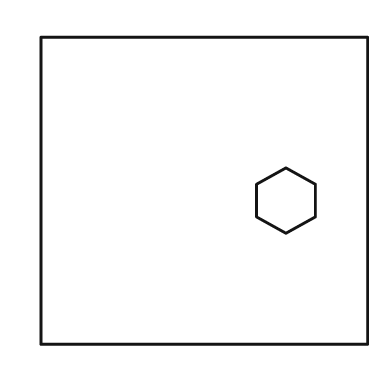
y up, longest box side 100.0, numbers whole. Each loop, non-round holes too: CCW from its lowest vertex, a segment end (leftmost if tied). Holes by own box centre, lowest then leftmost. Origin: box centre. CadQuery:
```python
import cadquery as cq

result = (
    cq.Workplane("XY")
    .moveTo(-50.0, -47.0)
    .lineTo(50.0, -47.0)
    .lineTo(50.0, 47.0)
    .lineTo(-50.0, 47.0)
    .close()
    .moveTo(25.0, -13.0)
    .lineTo(34.0, -8.0)
    .lineTo(34.0, 2.0)
    .lineTo(25.0, 7.0)
    .lineTo(16.0, 2.0)
    .lineTo(16.0, -8.0)
    .close()
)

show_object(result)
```